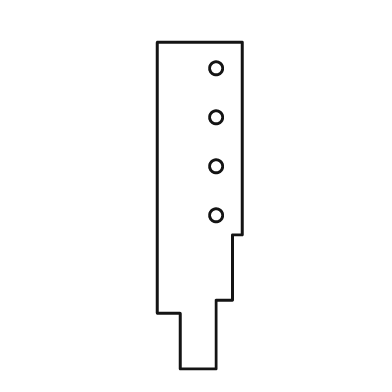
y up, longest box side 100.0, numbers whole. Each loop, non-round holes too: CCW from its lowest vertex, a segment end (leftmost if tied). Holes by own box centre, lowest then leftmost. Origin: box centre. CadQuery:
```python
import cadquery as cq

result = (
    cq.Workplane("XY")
    .moveTo(-6.0, -50.0)
    .lineTo(5.0, -50.0)
    .lineTo(5.0, -29.0)
    .lineTo(10.0, -29.0)
    .lineTo(10.0, -9.0)
    .lineTo(13.0, -9.0)
    .lineTo(13.0, 50.0)
    .lineTo(-13.0, 50.0)
    .lineTo(-13.0, -33.0)
    .lineTo(-6.0, -33.0)
    .close()
    .moveTo(5.0, -3.0)
    .circle(2.0)
    .moveTo(5.0, 12.0)
    .circle(2.0)
    .moveTo(5.0, 27.0)
    .circle(2.0)
    .moveTo(5.0, 42.0)
    .circle(2.0)
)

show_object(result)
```